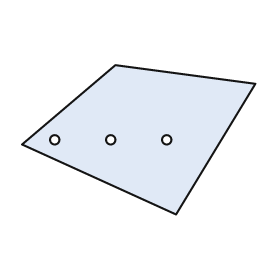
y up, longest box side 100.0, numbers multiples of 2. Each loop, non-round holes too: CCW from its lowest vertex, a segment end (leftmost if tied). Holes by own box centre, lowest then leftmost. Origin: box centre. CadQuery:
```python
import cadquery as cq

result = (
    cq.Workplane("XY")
    .moveTo(16.0, -32.0)
    .lineTo(50.0, 24.0)
    .lineTo(-10.0, 32.0)
    .lineTo(-50.0, -2.0)
    .close()
    .moveTo(-36.0, 0.0)
    .circle(2.0)
    .moveTo(-12.0, 0.0)
    .circle(2.0)
    .moveTo(12.0, 0.0)
    .circle(2.0)
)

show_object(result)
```